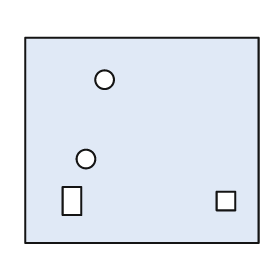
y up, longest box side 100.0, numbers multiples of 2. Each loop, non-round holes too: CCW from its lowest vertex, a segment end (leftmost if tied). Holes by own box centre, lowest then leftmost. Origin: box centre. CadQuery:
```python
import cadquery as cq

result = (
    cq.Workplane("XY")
    .moveTo(-50.0, -44.0)
    .lineTo(50.0, -44.0)
    .lineTo(50.0, 44.0)
    .lineTo(-50.0, 44.0)
    .close()
    .moveTo(-34.0, -32.0)
    .lineTo(-26.0, -32.0)
    .lineTo(-26.0, -20.0)
    .lineTo(-34.0, -20.0)
    .close()
    .moveTo(32.0, -30.0)
    .lineTo(40.0, -30.0)
    .lineTo(40.0, -22.0)
    .lineTo(32.0, -22.0)
    .close()
    .moveTo(-24.0, -8.0)
    .circle(4.0)
    .moveTo(-16.0, 26.0)
    .circle(4.0)
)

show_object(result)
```